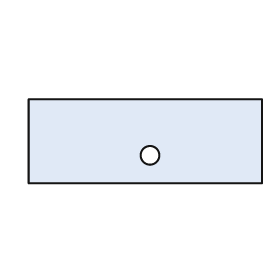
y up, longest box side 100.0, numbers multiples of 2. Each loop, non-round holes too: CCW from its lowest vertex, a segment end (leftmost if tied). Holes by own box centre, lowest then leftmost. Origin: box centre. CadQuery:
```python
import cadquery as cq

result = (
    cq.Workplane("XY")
    .moveTo(-50.0, -18.0)
    .lineTo(50.0, -18.0)
    .lineTo(50.0, 18.0)
    .lineTo(-50.0, 18.0)
    .close()
    .moveTo(2.0, -6.0)
    .circle(4.0)
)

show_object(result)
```